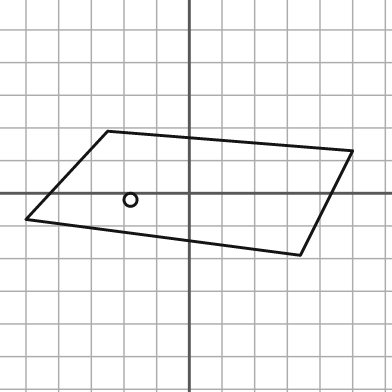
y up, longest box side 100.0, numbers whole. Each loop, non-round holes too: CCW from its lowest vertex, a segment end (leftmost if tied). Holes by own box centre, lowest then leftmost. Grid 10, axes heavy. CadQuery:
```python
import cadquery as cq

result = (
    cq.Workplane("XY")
    .moveTo(34.0, -19.0)
    .lineTo(50.0, 13.0)
    .lineTo(-25.0, 19.0)
    .lineTo(-50.0, -8.0)
    .close()
    .moveTo(-18.0, -2.0)
    .circle(2.0)
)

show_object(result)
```